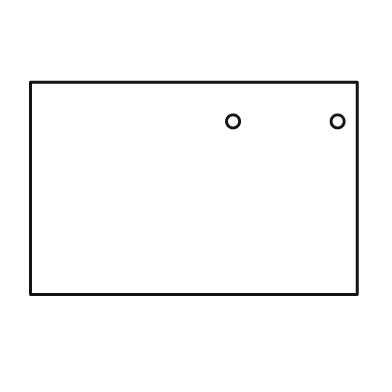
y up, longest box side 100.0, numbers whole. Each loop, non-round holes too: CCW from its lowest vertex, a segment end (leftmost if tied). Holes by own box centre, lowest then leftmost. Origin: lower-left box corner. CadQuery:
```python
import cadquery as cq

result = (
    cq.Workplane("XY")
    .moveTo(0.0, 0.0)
    .lineTo(100.0, 0.0)
    .lineTo(100.0, 65.0)
    .lineTo(0.0, 65.0)
    .close()
    .moveTo(62.0, 53.0)
    .circle(2.0)
    .moveTo(94.0, 53.0)
    .circle(2.0)
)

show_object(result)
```